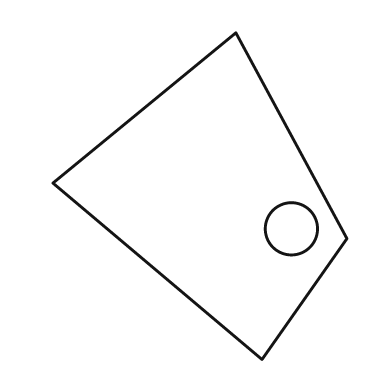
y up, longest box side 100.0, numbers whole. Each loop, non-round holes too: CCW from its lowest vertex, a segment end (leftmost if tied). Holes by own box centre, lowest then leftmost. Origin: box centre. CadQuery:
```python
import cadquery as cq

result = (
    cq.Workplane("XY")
    .moveTo(19.0, -50.0)
    .lineTo(45.0, -13.0)
    .lineTo(11.0, 50.0)
    .lineTo(-45.0, 4.0)
    .close()
    .moveTo(28.0, -10.0)
    .circle(8.0)
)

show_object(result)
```